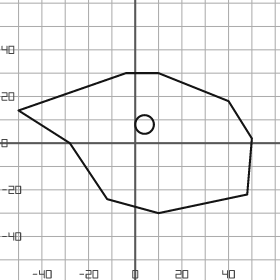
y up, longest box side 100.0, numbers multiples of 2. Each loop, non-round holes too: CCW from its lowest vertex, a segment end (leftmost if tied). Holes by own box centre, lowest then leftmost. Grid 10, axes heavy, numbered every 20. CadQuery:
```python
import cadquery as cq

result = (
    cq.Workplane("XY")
    .moveTo(10.0, -30.0)
    .lineTo(48.0, -22.0)
    .lineTo(50.0, 2.0)
    .lineTo(40.0, 18.0)
    .lineTo(10.0, 30.0)
    .lineTo(-4.0, 30.0)
    .lineTo(-50.0, 14.0)
    .lineTo(-28.0, 0.0)
    .lineTo(-12.0, -24.0)
    .close()
    .moveTo(4.0, 8.0)
    .circle(4.0)
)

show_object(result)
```